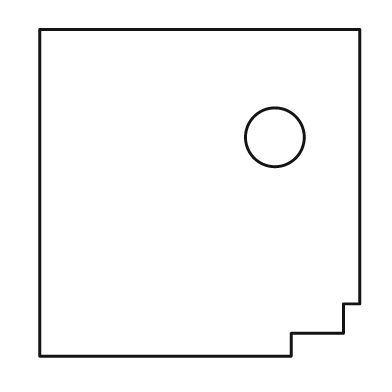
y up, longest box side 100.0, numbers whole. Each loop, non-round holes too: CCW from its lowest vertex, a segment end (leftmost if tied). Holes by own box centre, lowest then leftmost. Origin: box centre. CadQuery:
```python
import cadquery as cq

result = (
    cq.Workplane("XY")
    .moveTo(-49.0, -50.0)
    .lineTo(28.0, -50.0)
    .lineTo(28.0, -43.0)
    .lineTo(44.0, -43.0)
    .lineTo(44.0, -34.0)
    .lineTo(49.0, -34.0)
    .lineTo(49.0, 50.0)
    .lineTo(-49.0, 50.0)
    .close()
    .moveTo(23.0, 17.0)
    .circle(9.0)
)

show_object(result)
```